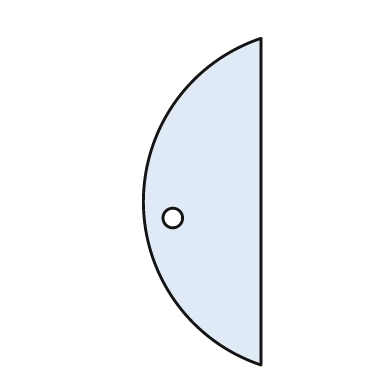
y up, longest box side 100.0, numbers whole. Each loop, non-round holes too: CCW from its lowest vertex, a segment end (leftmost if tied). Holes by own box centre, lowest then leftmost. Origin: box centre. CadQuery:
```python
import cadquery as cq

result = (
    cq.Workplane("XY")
    .moveTo(18.0, -50.0)
    .lineTo(18.0, 50.0)
    .threePointArc((-18.0, 0.0), (18.0, -50.0))
    .close()
    .moveTo(-9.0, -5.0)
    .circle(3.0)
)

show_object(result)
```